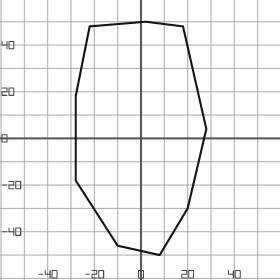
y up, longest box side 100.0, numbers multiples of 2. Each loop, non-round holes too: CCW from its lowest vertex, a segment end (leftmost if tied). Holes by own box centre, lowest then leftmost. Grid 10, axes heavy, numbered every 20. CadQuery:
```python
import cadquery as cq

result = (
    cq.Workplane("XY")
    .moveTo(8.0, -50.0)
    .lineTo(20.0, -30.0)
    .lineTo(28.0, 4.0)
    .lineTo(18.0, 48.0)
    .lineTo(2.0, 50.0)
    .lineTo(-22.0, 48.0)
    .lineTo(-28.0, 18.0)
    .lineTo(-28.0, -18.0)
    .lineTo(-10.0, -46.0)
    .close()
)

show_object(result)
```